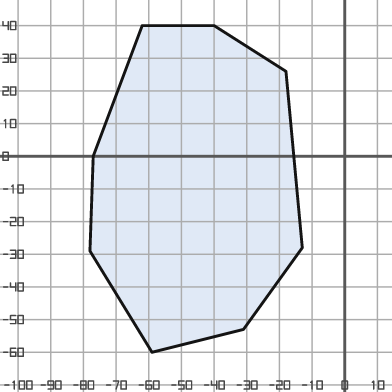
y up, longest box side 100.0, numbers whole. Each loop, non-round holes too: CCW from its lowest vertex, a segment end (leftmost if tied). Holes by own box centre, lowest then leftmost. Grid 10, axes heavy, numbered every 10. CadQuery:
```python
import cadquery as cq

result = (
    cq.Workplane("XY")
    .moveTo(-59.0, -60.0)
    .lineTo(-31.0, -53.0)
    .lineTo(-13.0, -28.0)
    .lineTo(-18.0, 26.0)
    .lineTo(-40.0, 40.0)
    .lineTo(-62.0, 40.0)
    .lineTo(-77.0, 0.0)
    .lineTo(-78.0, -29.0)
    .close()
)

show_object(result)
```